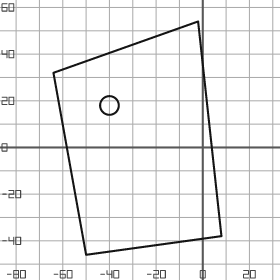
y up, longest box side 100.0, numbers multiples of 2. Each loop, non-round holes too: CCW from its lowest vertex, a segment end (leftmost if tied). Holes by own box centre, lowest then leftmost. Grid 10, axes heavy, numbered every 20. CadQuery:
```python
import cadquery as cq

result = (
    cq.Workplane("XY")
    .moveTo(-50.0, -46.0)
    .lineTo(8.0, -38.0)
    .lineTo(-2.0, 54.0)
    .lineTo(-64.0, 32.0)
    .close()
    .moveTo(-40.0, 18.0)
    .circle(4.0)
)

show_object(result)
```